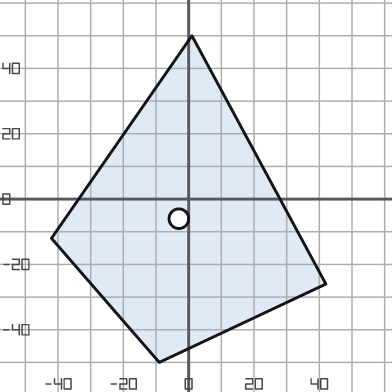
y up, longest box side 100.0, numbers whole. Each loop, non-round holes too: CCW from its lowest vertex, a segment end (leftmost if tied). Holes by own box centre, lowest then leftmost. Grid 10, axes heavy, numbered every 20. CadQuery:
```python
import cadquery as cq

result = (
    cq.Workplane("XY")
    .moveTo(-9.0, -50.0)
    .lineTo(42.0, -26.0)
    .lineTo(1.0, 50.0)
    .lineTo(-42.0, -12.0)
    .close()
    .moveTo(-3.0, -6.0)
    .circle(3.0)
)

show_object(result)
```